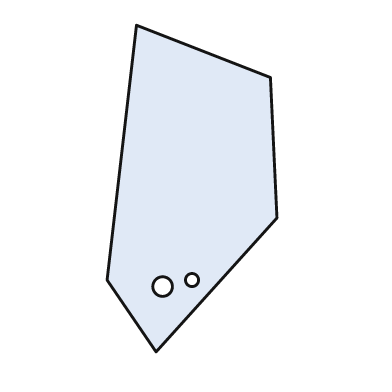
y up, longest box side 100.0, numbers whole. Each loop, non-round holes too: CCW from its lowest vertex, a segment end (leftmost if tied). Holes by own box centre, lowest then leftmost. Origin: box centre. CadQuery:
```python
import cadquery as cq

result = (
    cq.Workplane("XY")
    .moveTo(-11.0, -50.0)
    .lineTo(26.0, -9.0)
    .lineTo(24.0, 34.0)
    .lineTo(-17.0, 50.0)
    .lineTo(-26.0, -28.0)
    .close()
    .moveTo(-9.0, -30.0)
    .circle(3.0)
    .moveTo(0.0, -28.0)
    .circle(2.0)
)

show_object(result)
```